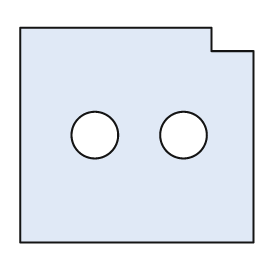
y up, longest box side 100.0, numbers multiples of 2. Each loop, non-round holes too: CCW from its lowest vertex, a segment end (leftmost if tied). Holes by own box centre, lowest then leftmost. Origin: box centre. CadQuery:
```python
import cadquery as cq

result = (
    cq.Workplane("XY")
    .moveTo(-50.0, -46.0)
    .lineTo(50.0, -46.0)
    .lineTo(50.0, 36.0)
    .lineTo(32.0, 36.0)
    .lineTo(32.0, 46.0)
    .lineTo(-50.0, 46.0)
    .close()
    .moveTo(-18.0, 0.0)
    .circle(10.0)
    .moveTo(20.0, 0.0)
    .circle(10.0)
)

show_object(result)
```